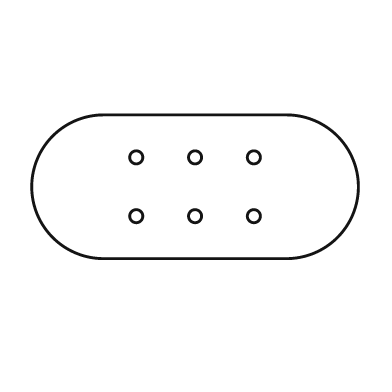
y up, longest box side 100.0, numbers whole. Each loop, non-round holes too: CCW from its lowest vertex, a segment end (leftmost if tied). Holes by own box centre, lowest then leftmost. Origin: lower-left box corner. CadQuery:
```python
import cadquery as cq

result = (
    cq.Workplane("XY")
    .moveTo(22.0, 0.0)
    .lineTo(78.0, 0.0)
    .threePointArc((100.0, 22.0), (78.0, 44.0))
    .lineTo(22.0, 44.0)
    .threePointArc((0.0, 22.0), (22.0, 0.0))
    .close()
    .moveTo(32.0, 13.0)
    .circle(2.0)
    .moveTo(50.0, 13.0)
    .circle(2.0)
    .moveTo(68.0, 13.0)
    .circle(2.0)
    .moveTo(32.0, 31.0)
    .circle(2.0)
    .moveTo(50.0, 31.0)
    .circle(2.0)
    .moveTo(68.0, 31.0)
    .circle(2.0)
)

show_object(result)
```